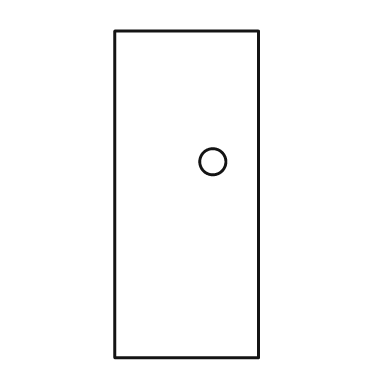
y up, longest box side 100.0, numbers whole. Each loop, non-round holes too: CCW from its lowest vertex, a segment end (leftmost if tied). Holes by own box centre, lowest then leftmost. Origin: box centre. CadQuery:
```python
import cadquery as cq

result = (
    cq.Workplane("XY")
    .moveTo(-22.0, -50.0)
    .lineTo(22.0, -50.0)
    .lineTo(22.0, 50.0)
    .lineTo(-22.0, 50.0)
    .close()
    .moveTo(8.0, 10.0)
    .circle(4.0)
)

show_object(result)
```